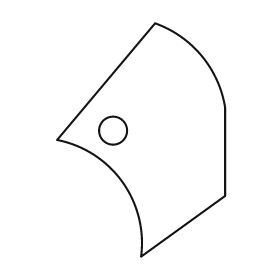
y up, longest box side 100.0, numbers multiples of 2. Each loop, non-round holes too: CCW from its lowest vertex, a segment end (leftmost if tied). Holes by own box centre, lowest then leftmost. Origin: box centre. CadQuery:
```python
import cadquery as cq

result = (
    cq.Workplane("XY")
    .moveTo(0.0, -50.0)
    .lineTo(36.0, -24.0)
    .lineTo(36.0, 14.0)
    .threePointArc((26.0, 36.0), (6.0, 50.0))
    .lineTo(-36.0, 0.0)
    .threePointArc((-8.0, -18.0), (0.0, -50.0))
    .close()
    .moveTo(-12.0, 4.0)
    .circle(6.0)
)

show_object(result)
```